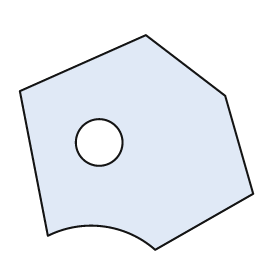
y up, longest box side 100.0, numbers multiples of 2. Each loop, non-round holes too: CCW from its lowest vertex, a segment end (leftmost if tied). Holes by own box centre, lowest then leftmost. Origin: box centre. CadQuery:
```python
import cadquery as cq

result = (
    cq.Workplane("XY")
    .moveTo(8.0, -46.0)
    .lineTo(50.0, -22.0)
    .lineTo(38.0, 20.0)
    .lineTo(4.0, 46.0)
    .lineTo(-50.0, 22.0)
    .lineTo(-38.0, -40.0)
    .threePointArc((-14.0, -36.0), (8.0, -46.0))
    .close()
    .moveTo(-16.0, 0.0)
    .circle(10.0)
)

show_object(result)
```